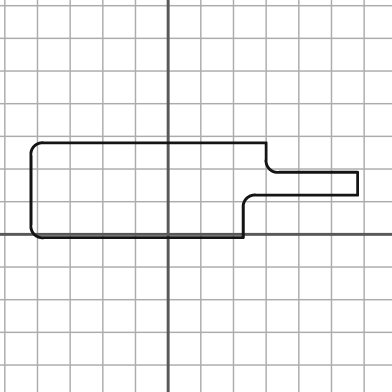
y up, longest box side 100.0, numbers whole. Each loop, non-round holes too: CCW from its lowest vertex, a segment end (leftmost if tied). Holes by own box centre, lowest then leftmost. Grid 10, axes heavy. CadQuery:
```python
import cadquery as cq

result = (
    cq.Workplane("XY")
    .moveTo(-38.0, -1.0)
    .lineTo(23.0, -1.0)
    .lineTo(23.0, 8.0)
    .threePointArc((24.0, 11.0), (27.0, 12.0))
    .lineTo(58.0, 12.0)
    .lineTo(58.0, 19.0)
    .lineTo(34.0, 19.0)
    .threePointArc((31.0, 20.0), (30.0, 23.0))
    .lineTo(30.0, 28.0)
    .lineTo(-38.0, 28.0)
    .threePointArc((-41.0, 27.0), (-42.0, 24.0))
    .lineTo(-42.0, 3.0)
    .threePointArc((-41.0, 0.0), (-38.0, -1.0))
    .close()
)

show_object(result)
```